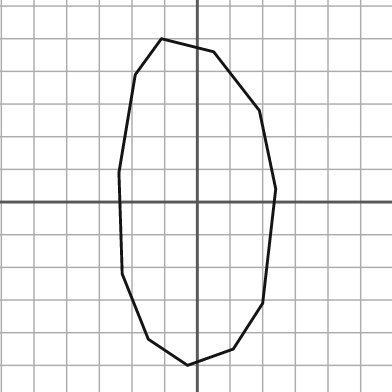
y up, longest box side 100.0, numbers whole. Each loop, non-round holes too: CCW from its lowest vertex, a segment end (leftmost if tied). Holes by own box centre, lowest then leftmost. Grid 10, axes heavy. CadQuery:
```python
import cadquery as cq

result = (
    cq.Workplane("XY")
    .moveTo(-3.0, -50.0)
    .lineTo(11.0, -45.0)
    .lineTo(20.0, -31.0)
    .lineTo(24.0, 4.0)
    .lineTo(19.0, 28.0)
    .lineTo(5.0, 46.0)
    .lineTo(-11.0, 50.0)
    .lineTo(-19.0, 39.0)
    .lineTo(-24.0, 9.0)
    .lineTo(-23.0, -22.0)
    .lineTo(-15.0, -42.0)
    .close()
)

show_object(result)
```